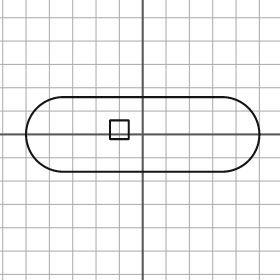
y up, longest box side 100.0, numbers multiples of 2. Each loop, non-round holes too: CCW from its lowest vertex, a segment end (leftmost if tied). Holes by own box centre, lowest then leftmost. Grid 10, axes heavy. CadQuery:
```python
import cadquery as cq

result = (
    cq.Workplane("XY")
    .moveTo(-34.0, -16.0)
    .lineTo(34.0, -16.0)
    .threePointArc((50.0, 0.0), (34.0, 16.0))
    .lineTo(-34.0, 16.0)
    .threePointArc((-50.0, 0.0), (-34.0, -16.0))
    .close()
    .moveTo(-14.0, -2.0)
    .lineTo(-6.0, -2.0)
    .lineTo(-6.0, 6.0)
    .lineTo(-14.0, 6.0)
    .close()
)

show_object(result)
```